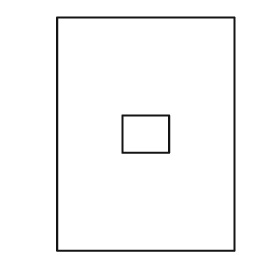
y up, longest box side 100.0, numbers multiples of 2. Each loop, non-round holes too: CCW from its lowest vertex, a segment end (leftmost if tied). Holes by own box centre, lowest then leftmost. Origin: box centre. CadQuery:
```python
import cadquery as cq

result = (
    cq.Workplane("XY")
    .moveTo(-38.0, -50.0)
    .lineTo(38.0, -50.0)
    .lineTo(38.0, 50.0)
    .lineTo(-38.0, 50.0)
    .close()
    .moveTo(-10.0, -8.0)
    .lineTo(10.0, -8.0)
    .lineTo(10.0, 8.0)
    .lineTo(-10.0, 8.0)
    .close()
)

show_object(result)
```